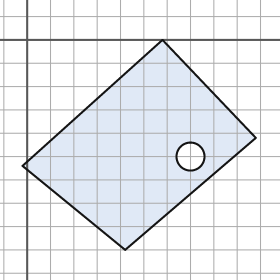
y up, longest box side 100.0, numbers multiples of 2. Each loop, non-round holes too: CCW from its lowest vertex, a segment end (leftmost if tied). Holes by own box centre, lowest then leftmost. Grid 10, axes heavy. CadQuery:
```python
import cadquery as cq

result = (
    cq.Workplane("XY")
    .moveTo(42.0, -90.0)
    .lineTo(98.0, -42.0)
    .lineTo(58.0, 0.0)
    .lineTo(-2.0, -54.0)
    .close()
    .moveTo(70.0, -50.0)
    .circle(6.0)
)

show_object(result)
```